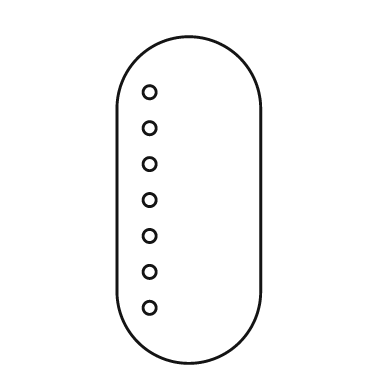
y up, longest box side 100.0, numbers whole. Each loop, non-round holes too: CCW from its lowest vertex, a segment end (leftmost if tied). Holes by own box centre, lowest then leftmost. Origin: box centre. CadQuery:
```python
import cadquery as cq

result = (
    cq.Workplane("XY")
    .moveTo(-22.0, -28.0)
    .threePointArc((0.0, -50.0), (22.0, -28.0))
    .lineTo(22.0, 28.0)
    .threePointArc((0.0, 50.0), (-22.0, 28.0))
    .close()
    .moveTo(-12.0, -33.0)
    .circle(2.0)
    .moveTo(-12.0, -22.0)
    .circle(2.0)
    .moveTo(-12.0, -11.0)
    .circle(2.0)
    .moveTo(-12.0, 0.0)
    .circle(2.0)
    .moveTo(-12.0, 11.0)
    .circle(2.0)
    .moveTo(-12.0, 22.0)
    .circle(2.0)
    .moveTo(-12.0, 33.0)
    .circle(2.0)
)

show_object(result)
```